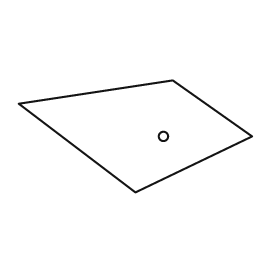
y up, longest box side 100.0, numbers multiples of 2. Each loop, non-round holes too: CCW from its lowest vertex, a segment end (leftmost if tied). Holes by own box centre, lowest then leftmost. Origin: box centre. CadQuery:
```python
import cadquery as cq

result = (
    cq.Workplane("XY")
    .moveTo(0.0, -24.0)
    .lineTo(50.0, 0.0)
    .lineTo(16.0, 24.0)
    .lineTo(-50.0, 14.0)
    .close()
    .moveTo(12.0, 0.0)
    .circle(2.0)
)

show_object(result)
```